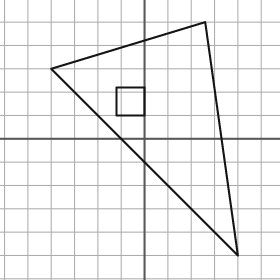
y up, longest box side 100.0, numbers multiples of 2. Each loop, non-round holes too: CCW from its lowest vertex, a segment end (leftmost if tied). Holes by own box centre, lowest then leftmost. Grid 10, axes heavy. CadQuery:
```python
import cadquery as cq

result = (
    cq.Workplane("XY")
    .moveTo(40.0, -50.0)
    .lineTo(26.0, 50.0)
    .lineTo(-40.0, 30.0)
    .close()
    .moveTo(-12.0, 10.0)
    .lineTo(0.0, 10.0)
    .lineTo(0.0, 22.0)
    .lineTo(-12.0, 22.0)
    .close()
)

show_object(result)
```